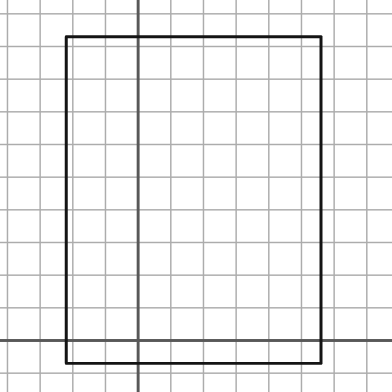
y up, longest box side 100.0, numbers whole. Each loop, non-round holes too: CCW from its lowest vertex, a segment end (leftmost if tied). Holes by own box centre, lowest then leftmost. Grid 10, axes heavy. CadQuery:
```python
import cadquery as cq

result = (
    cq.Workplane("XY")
    .moveTo(-22.0, -7.0)
    .lineTo(56.0, -7.0)
    .lineTo(56.0, 93.0)
    .lineTo(-22.0, 93.0)
    .close()
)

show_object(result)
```